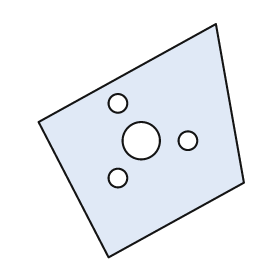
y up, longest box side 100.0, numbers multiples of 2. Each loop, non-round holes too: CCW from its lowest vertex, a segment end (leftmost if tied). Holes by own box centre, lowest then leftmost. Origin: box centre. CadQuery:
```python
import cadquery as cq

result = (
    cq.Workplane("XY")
    .moveTo(-14.0, -50.0)
    .lineTo(44.0, -18.0)
    .lineTo(32.0, 50.0)
    .lineTo(-44.0, 8.0)
    .close()
    .moveTo(-10.0, -16.0)
    .circle(4.0)
    .moveTo(0.0, 0.0)
    .circle(8.0)
    .moveTo(20.0, 0.0)
    .circle(4.0)
    .moveTo(-10.0, 16.0)
    .circle(4.0)
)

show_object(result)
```